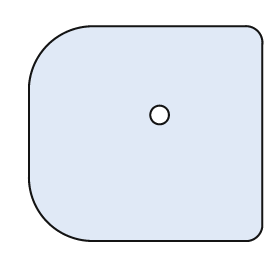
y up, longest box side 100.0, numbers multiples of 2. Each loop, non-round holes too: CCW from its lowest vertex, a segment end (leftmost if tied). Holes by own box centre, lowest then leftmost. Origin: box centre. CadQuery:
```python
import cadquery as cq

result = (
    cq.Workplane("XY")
    .moveTo(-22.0, -46.0)
    .lineTo(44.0, -46.0)
    .threePointArc((48.0, -44.0), (50.0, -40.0))
    .lineTo(50.0, 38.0)
    .threePointArc((48.0, 44.0), (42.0, 46.0))
    .lineTo(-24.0, 46.0)
    .threePointArc((-42.0, 38.0), (-50.0, 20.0))
    .lineTo(-50.0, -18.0)
    .threePointArc((-42.0, -38.0), (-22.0, -46.0))
    .close()
    .moveTo(6.0, 8.0)
    .circle(4.0)
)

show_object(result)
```